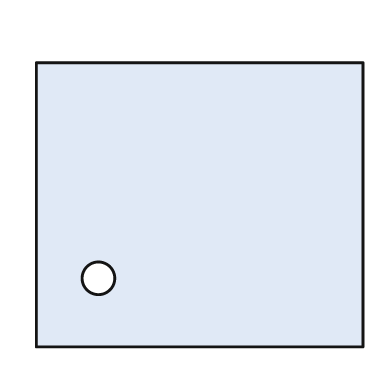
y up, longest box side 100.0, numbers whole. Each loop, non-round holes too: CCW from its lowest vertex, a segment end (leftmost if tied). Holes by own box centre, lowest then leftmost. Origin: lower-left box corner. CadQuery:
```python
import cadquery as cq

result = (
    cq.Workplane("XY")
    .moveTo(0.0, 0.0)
    .lineTo(100.0, 0.0)
    .lineTo(100.0, 87.0)
    .lineTo(0.0, 87.0)
    .close()
    .moveTo(19.0, 21.0)
    .circle(5.0)
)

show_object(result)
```